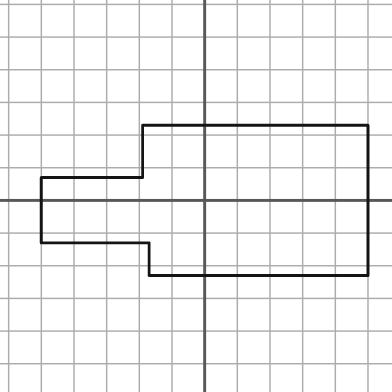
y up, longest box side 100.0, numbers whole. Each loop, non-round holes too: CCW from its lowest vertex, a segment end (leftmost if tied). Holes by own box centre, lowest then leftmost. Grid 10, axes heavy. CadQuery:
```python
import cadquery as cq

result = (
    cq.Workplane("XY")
    .moveTo(-17.0, -23.0)
    .lineTo(50.0, -23.0)
    .lineTo(50.0, 23.0)
    .lineTo(-19.0, 23.0)
    .lineTo(-19.0, 7.0)
    .lineTo(-50.0, 7.0)
    .lineTo(-50.0, -13.0)
    .lineTo(-17.0, -13.0)
    .close()
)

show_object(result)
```